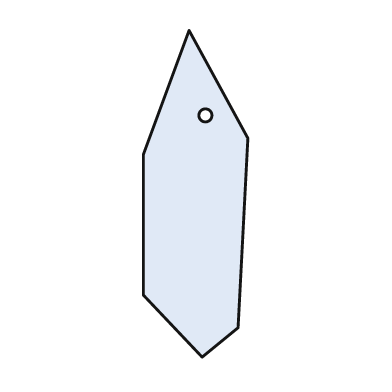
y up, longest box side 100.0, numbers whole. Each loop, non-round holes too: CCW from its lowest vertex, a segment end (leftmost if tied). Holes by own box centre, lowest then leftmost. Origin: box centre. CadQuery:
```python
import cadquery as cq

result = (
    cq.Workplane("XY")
    .moveTo(2.0, -50.0)
    .lineTo(13.0, -41.0)
    .lineTo(16.0, 17.0)
    .lineTo(-2.0, 50.0)
    .lineTo(-16.0, 12.0)
    .lineTo(-16.0, -31.0)
    .close()
    .moveTo(3.0, 24.0)
    .circle(2.0)
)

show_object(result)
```